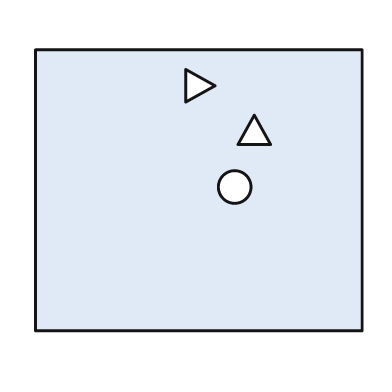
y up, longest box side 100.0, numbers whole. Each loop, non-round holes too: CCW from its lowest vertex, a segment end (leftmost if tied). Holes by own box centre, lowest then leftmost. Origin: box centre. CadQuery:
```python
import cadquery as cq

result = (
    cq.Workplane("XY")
    .moveTo(-50.0, -43.0)
    .lineTo(50.0, -43.0)
    .lineTo(50.0, 43.0)
    .lineTo(-50.0, 43.0)
    .close()
    .moveTo(11.0, 1.0)
    .circle(5.0)
    .moveTo(12.0, 14.0)
    .lineTo(22.0, 14.0)
    .lineTo(17.0, 23.0)
    .close()
    .moveTo(-4.0, 27.0)
    .lineTo(5.0, 32.0)
    .lineTo(-4.0, 37.0)
    .close()
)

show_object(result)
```